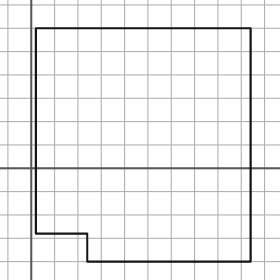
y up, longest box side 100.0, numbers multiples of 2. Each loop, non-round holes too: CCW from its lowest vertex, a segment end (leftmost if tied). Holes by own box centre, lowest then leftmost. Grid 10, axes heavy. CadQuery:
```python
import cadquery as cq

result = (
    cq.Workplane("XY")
    .moveTo(24.0, -40.0)
    .lineTo(94.0, -40.0)
    .lineTo(94.0, 60.0)
    .lineTo(2.0, 60.0)
    .lineTo(2.0, -28.0)
    .lineTo(24.0, -28.0)
    .close()
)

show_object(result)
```